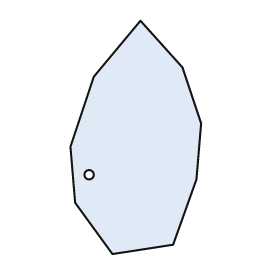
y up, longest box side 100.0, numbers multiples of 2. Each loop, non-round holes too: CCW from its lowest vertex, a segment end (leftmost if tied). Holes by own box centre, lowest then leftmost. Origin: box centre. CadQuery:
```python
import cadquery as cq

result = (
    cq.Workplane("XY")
    .moveTo(-10.0, -50.0)
    .lineTo(16.0, -46.0)
    .lineTo(26.0, -18.0)
    .lineTo(28.0, 6.0)
    .lineTo(20.0, 30.0)
    .lineTo(2.0, 50.0)
    .lineTo(-18.0, 26.0)
    .lineTo(-28.0, -4.0)
    .lineTo(-26.0, -28.0)
    .close()
    .moveTo(-20.0, -16.0)
    .circle(2.0)
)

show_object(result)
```